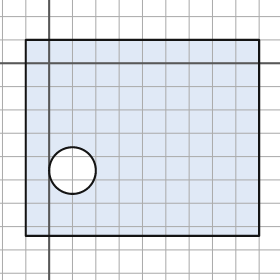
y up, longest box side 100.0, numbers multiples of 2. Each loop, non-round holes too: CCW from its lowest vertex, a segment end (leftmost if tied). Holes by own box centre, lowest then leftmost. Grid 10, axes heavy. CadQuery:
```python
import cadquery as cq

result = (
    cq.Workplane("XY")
    .moveTo(-10.0, -74.0)
    .lineTo(90.0, -74.0)
    .lineTo(90.0, 10.0)
    .lineTo(-10.0, 10.0)
    .close()
    .moveTo(10.0, -46.0)
    .circle(10.0)
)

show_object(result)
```